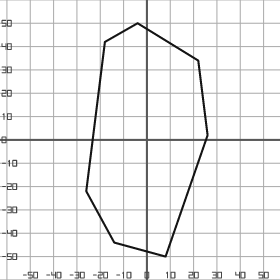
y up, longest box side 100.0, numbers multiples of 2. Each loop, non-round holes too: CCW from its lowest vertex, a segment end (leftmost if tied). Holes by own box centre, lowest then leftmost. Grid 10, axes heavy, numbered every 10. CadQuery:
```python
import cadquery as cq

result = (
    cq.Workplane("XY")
    .moveTo(8.0, -50.0)
    .lineTo(26.0, 2.0)
    .lineTo(22.0, 34.0)
    .lineTo(-4.0, 50.0)
    .lineTo(-18.0, 42.0)
    .lineTo(-26.0, -22.0)
    .lineTo(-14.0, -44.0)
    .close()
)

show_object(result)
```